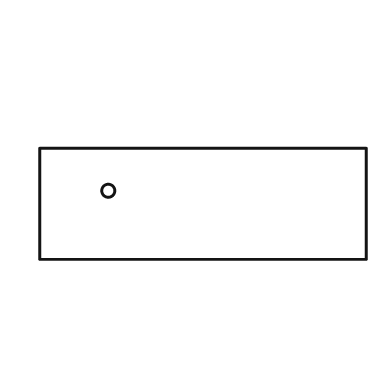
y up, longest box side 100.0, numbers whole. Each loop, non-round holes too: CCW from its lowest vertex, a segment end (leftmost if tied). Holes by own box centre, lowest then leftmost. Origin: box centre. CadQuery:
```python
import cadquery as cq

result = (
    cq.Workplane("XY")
    .moveTo(-50.0, -17.0)
    .lineTo(50.0, -17.0)
    .lineTo(50.0, 17.0)
    .lineTo(-50.0, 17.0)
    .close()
    .moveTo(-29.0, 4.0)
    .circle(2.0)
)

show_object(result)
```